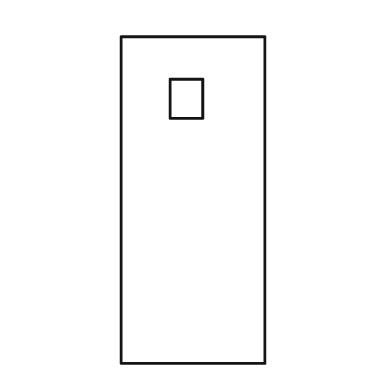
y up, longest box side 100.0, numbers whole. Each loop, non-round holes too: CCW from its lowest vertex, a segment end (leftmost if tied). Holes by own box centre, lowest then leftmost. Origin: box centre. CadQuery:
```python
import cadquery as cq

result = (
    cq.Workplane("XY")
    .moveTo(-22.0, -50.0)
    .lineTo(22.0, -50.0)
    .lineTo(22.0, 50.0)
    .lineTo(-22.0, 50.0)
    .close()
    .moveTo(-7.0, 25.0)
    .lineTo(3.0, 25.0)
    .lineTo(3.0, 37.0)
    .lineTo(-7.0, 37.0)
    .close()
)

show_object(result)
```